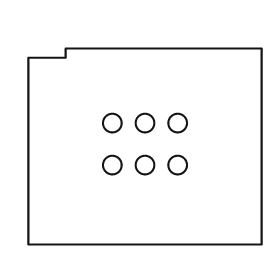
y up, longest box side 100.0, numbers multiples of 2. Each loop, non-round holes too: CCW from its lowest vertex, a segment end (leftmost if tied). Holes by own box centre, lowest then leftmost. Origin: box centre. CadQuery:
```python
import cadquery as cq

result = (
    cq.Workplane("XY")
    .moveTo(-50.0, -42.0)
    .lineTo(50.0, -42.0)
    .lineTo(50.0, 42.0)
    .lineTo(-34.0, 42.0)
    .lineTo(-34.0, 38.0)
    .lineTo(-50.0, 38.0)
    .close()
    .moveTo(-14.0, -8.0)
    .circle(4.0)
    .moveTo(0.0, -8.0)
    .circle(4.0)
    .moveTo(14.0, -8.0)
    .circle(4.0)
    .moveTo(-14.0, 10.0)
    .circle(4.0)
    .moveTo(0.0, 10.0)
    .circle(4.0)
    .moveTo(14.0, 10.0)
    .circle(4.0)
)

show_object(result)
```